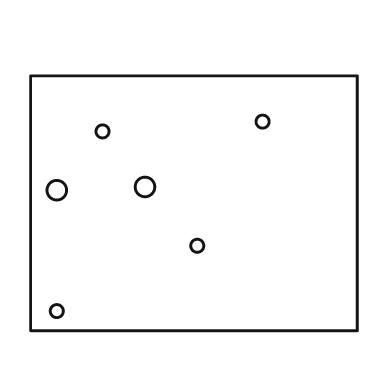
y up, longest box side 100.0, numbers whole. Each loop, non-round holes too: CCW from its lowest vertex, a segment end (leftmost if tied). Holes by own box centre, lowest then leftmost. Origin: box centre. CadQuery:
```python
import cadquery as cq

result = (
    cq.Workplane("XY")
    .moveTo(-50.0, -39.0)
    .lineTo(50.0, -39.0)
    .lineTo(50.0, 39.0)
    .lineTo(-50.0, 39.0)
    .close()
    .moveTo(-42.0, -33.0)
    .circle(2.0)
    .moveTo(1.0, -13.0)
    .circle(2.0)
    .moveTo(-42.0, 4.0)
    .circle(3.0)
    .moveTo(-15.0, 5.0)
    .circle(3.0)
    .moveTo(-28.0, 22.0)
    .circle(2.0)
    .moveTo(21.0, 25.0)
    .circle(2.0)
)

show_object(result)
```